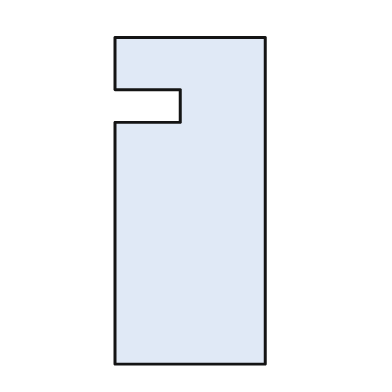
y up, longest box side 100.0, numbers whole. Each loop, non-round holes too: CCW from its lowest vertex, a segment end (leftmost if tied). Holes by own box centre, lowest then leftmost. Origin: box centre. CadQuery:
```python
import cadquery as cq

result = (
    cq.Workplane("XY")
    .moveTo(-23.0, -50.0)
    .lineTo(23.0, -50.0)
    .lineTo(23.0, 50.0)
    .lineTo(-23.0, 50.0)
    .lineTo(-23.0, 34.0)
    .lineTo(-3.0, 34.0)
    .lineTo(-3.0, 24.0)
    .lineTo(-23.0, 24.0)
    .close()
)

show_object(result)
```